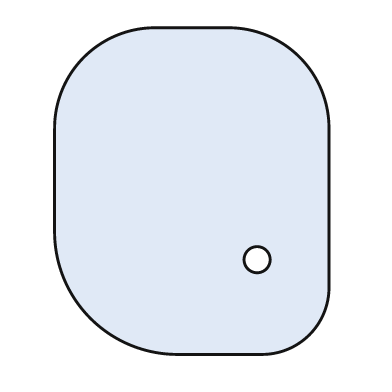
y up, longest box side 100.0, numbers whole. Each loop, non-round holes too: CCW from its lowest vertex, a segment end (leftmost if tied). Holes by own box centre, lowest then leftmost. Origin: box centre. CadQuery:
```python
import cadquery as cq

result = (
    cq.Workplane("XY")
    .moveTo(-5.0, -50.0)
    .lineTo(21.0, -50.0)
    .threePointArc((36.0, -44.0), (42.0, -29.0))
    .lineTo(42.0, 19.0)
    .threePointArc((33.0, 41.0), (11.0, 50.0))
    .lineTo(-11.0, 50.0)
    .threePointArc((-33.0, 41.0), (-42.0, 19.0))
    .lineTo(-42.0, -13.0)
    .threePointArc((-31.0, -39.0), (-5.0, -50.0))
    .close()
    .moveTo(20.0, -21.0)
    .circle(4.0)
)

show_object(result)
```